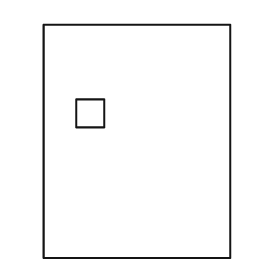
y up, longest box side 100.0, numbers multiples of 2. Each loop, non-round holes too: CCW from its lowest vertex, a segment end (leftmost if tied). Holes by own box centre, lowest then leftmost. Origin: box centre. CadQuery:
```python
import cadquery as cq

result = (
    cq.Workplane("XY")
    .moveTo(-40.0, -50.0)
    .lineTo(40.0, -50.0)
    .lineTo(40.0, 50.0)
    .lineTo(-40.0, 50.0)
    .close()
    .moveTo(-26.0, 6.0)
    .lineTo(-14.0, 6.0)
    .lineTo(-14.0, 18.0)
    .lineTo(-26.0, 18.0)
    .close()
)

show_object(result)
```